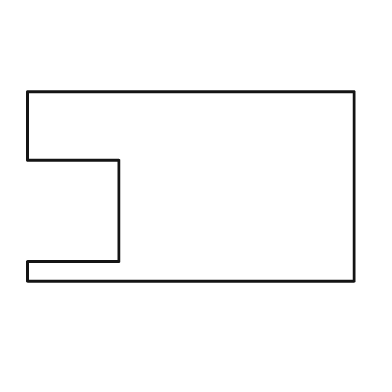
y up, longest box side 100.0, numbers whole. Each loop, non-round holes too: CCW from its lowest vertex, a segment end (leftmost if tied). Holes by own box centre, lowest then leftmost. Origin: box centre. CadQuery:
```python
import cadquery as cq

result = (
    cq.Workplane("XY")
    .moveTo(-50.0, -29.0)
    .lineTo(50.0, -29.0)
    .lineTo(50.0, 29.0)
    .lineTo(-50.0, 29.0)
    .lineTo(-50.0, 8.0)
    .lineTo(-22.0, 8.0)
    .lineTo(-22.0, -23.0)
    .lineTo(-50.0, -23.0)
    .close()
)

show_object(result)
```